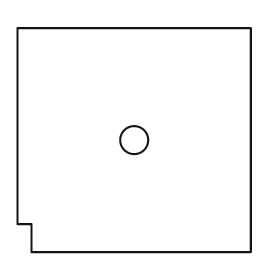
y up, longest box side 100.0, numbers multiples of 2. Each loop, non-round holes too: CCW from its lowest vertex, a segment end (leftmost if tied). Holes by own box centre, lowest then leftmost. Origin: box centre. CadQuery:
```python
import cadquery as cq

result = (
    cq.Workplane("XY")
    .moveTo(-44.0, -48.0)
    .lineTo(50.0, -48.0)
    .lineTo(50.0, 48.0)
    .lineTo(-50.0, 48.0)
    .lineTo(-50.0, -36.0)
    .lineTo(-44.0, -36.0)
    .close()
    .moveTo(0.0, 0.0)
    .circle(6.0)
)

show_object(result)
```